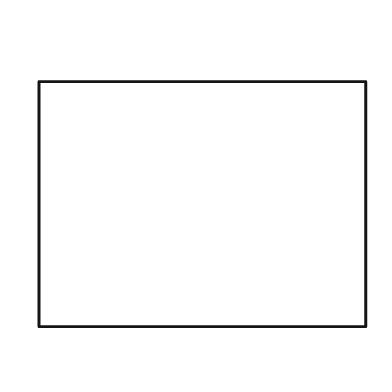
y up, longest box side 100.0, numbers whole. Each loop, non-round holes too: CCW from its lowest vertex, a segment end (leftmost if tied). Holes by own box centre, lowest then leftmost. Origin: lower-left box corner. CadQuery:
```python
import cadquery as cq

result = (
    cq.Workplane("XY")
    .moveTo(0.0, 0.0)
    .lineTo(100.0, 0.0)
    .lineTo(100.0, 75.0)
    .lineTo(0.0, 75.0)
    .close()
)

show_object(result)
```